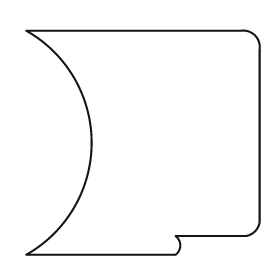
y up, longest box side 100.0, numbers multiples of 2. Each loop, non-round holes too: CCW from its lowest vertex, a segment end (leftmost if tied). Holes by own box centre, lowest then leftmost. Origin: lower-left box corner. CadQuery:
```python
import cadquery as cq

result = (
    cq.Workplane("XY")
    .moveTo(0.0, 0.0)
    .lineTo(64.0, 0.0)
    .threePointArc((66.0, 4.0), (64.0, 8.0))
    .lineTo(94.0, 8.0)
    .threePointArc((98.0, 10.0), (100.0, 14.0))
    .lineTo(100.0, 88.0)
    .threePointArc((98.0, 94.0), (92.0, 96.0))
    .lineTo(0.0, 96.0)
    .threePointArc((28.0, 48.0), (0.0, 0.0))
    .close()
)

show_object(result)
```